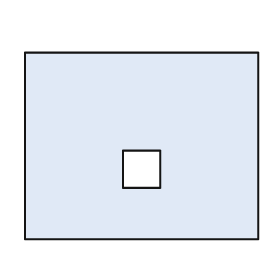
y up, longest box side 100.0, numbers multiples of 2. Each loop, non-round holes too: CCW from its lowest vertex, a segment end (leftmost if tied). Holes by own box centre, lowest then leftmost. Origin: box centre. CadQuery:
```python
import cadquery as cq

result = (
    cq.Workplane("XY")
    .moveTo(-50.0, -40.0)
    .lineTo(50.0, -40.0)
    .lineTo(50.0, 40.0)
    .lineTo(-50.0, 40.0)
    .close()
    .moveTo(-8.0, -18.0)
    .lineTo(8.0, -18.0)
    .lineTo(8.0, -2.0)
    .lineTo(-8.0, -2.0)
    .close()
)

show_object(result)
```